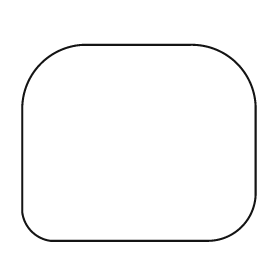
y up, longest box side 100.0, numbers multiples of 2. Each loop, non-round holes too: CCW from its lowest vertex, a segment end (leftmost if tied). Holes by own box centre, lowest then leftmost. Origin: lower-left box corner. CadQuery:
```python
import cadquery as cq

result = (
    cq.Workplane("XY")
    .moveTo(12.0, 0.0)
    .lineTo(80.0, 0.0)
    .threePointArc((94.0, 6.0), (100.0, 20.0))
    .lineTo(100.0, 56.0)
    .threePointArc((92.0, 76.0), (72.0, 84.0))
    .lineTo(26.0, 84.0)
    .threePointArc((8.0, 76.0), (0.0, 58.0))
    .lineTo(0.0, 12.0)
    .threePointArc((4.0, 4.0), (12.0, 0.0))
    .close()
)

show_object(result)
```